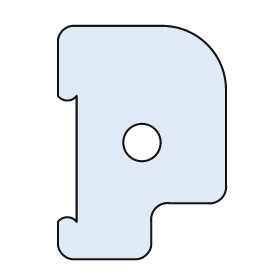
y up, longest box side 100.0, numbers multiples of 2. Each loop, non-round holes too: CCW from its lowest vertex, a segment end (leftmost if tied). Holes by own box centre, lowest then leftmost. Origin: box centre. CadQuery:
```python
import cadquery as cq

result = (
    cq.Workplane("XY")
    .moveTo(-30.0, -50.0)
    .lineTo(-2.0, -50.0)
    .threePointArc((2.0, -48.0), (4.0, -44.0))
    .lineTo(4.0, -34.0)
    .threePointArc((6.0, -28.0), (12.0, -26.0))
    .lineTo(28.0, -26.0)
    .threePointArc((34.0, -24.0), (36.0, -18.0))
    .lineTo(36.0, 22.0)
    .threePointArc((28.0, 42.0), (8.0, 50.0))
    .lineTo(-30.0, 50.0)
    .threePointArc((-34.0, 48.0), (-36.0, 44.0))
    .lineTo(-36.0, 20.0)
    .threePointArc((-32.0, 18.0), (-28.0, 20.0))
    .lineTo(-28.0, -34.0)
    .threePointArc((-32.0, -32.0), (-36.0, -34.0))
    .lineTo(-36.0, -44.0)
    .threePointArc((-34.0, -48.0), (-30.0, -50.0))
    .close()
    .moveTo(0.0, 0.0)
    .circle(8.0)
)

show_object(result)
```